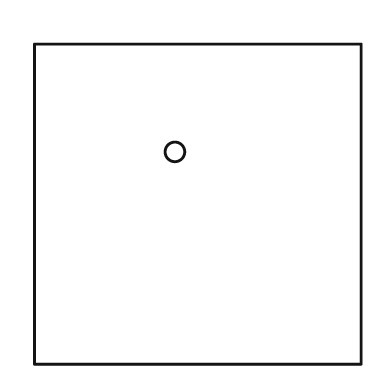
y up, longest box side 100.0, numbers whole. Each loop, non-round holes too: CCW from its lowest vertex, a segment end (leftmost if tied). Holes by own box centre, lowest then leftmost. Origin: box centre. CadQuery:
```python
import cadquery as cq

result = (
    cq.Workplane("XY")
    .moveTo(-50.0, -49.0)
    .lineTo(50.0, -49.0)
    .lineTo(50.0, 49.0)
    .lineTo(-50.0, 49.0)
    .close()
    .moveTo(-7.0, 16.0)
    .circle(3.0)
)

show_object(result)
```